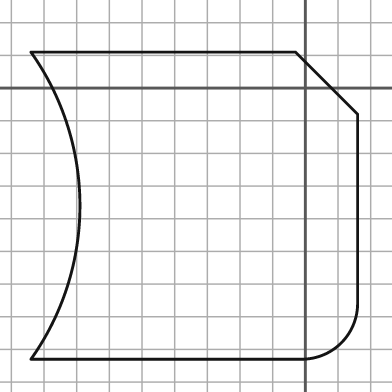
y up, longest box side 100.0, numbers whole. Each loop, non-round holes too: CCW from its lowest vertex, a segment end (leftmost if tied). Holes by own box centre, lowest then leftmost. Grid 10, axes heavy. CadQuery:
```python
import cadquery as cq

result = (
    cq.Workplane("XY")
    .moveTo(-84.0, -83.0)
    .lineTo(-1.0, -83.0)
    .threePointArc((11.0, -78.0), (16.0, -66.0))
    .lineTo(16.0, -8.0)
    .lineTo(-3.0, 11.0)
    .lineTo(-84.0, 11.0)
    .threePointArc((-69.0, -36.0), (-84.0, -83.0))
    .close()
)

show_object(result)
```